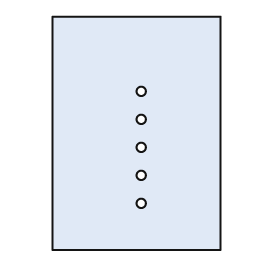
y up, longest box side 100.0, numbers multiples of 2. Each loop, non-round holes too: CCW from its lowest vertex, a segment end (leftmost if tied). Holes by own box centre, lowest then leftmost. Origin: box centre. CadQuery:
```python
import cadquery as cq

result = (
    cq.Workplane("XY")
    .moveTo(-36.0, -50.0)
    .lineTo(36.0, -50.0)
    .lineTo(36.0, 50.0)
    .lineTo(-36.0, 50.0)
    .close()
    .moveTo(2.0, -30.0)
    .circle(2.0)
    .moveTo(2.0, -18.0)
    .circle(2.0)
    .moveTo(2.0, -6.0)
    .circle(2.0)
    .moveTo(2.0, 6.0)
    .circle(2.0)
    .moveTo(2.0, 18.0)
    .circle(2.0)
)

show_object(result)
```